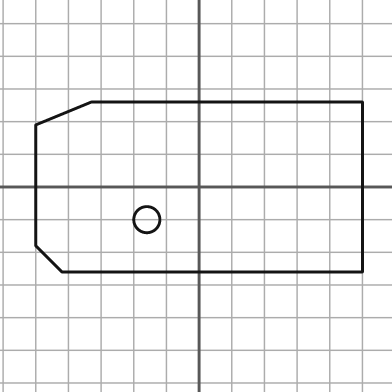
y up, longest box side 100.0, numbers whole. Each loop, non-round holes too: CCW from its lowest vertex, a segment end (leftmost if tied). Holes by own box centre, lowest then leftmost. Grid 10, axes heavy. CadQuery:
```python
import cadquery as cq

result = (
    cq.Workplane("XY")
    .moveTo(-42.0, -26.0)
    .lineTo(50.0, -26.0)
    .lineTo(50.0, 26.0)
    .lineTo(-33.0, 26.0)
    .lineTo(-50.0, 19.0)
    .lineTo(-50.0, -18.0)
    .close()
    .moveTo(-16.0, -10.0)
    .circle(4.0)
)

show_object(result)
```